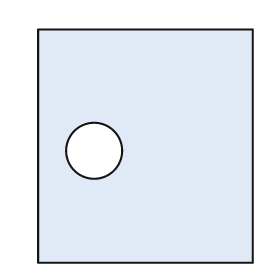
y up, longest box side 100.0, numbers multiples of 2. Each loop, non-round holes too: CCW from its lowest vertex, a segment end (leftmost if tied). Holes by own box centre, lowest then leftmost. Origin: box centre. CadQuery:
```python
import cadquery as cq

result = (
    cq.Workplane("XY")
    .moveTo(-46.0, -50.0)
    .lineTo(46.0, -50.0)
    .lineTo(46.0, 50.0)
    .lineTo(-46.0, 50.0)
    .close()
    .moveTo(-22.0, -2.0)
    .circle(12.0)
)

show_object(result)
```